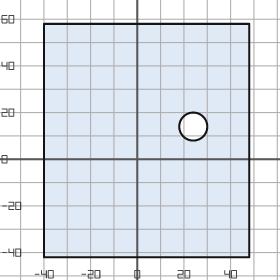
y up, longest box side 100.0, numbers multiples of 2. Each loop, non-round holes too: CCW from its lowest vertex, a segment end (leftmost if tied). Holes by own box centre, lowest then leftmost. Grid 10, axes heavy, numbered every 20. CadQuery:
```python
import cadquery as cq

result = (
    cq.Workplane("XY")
    .moveTo(-40.0, -42.0)
    .lineTo(48.0, -42.0)
    .lineTo(48.0, 58.0)
    .lineTo(-40.0, 58.0)
    .close()
    .moveTo(24.0, 14.0)
    .circle(6.0)
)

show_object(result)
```